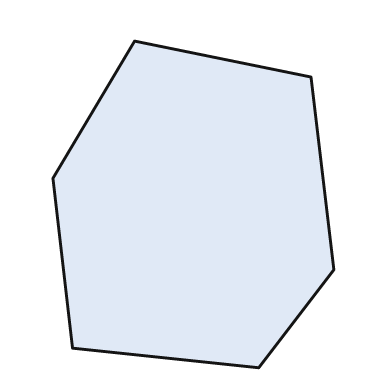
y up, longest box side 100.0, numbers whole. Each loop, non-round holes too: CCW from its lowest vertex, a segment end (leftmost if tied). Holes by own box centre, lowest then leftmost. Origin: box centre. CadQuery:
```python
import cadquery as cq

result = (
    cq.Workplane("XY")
    .moveTo(20.0, -50.0)
    .lineTo(43.0, -20.0)
    .lineTo(36.0, 39.0)
    .lineTo(-18.0, 50.0)
    .lineTo(-43.0, 8.0)
    .lineTo(-37.0, -44.0)
    .close()
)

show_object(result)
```